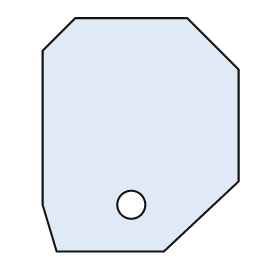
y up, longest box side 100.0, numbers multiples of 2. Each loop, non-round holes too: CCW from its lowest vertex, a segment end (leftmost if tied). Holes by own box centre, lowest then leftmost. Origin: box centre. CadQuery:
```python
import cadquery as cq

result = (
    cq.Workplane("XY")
    .moveTo(-36.0, -50.0)
    .lineTo(10.0, -50.0)
    .lineTo(42.0, -20.0)
    .lineTo(42.0, 28.0)
    .lineTo(20.0, 50.0)
    .lineTo(-28.0, 50.0)
    .lineTo(-42.0, 36.0)
    .lineTo(-42.0, -30.0)
    .close()
    .moveTo(-4.0, -30.0)
    .circle(6.0)
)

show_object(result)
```